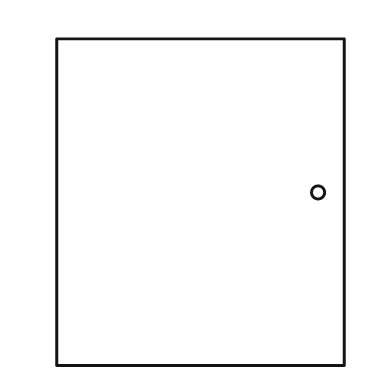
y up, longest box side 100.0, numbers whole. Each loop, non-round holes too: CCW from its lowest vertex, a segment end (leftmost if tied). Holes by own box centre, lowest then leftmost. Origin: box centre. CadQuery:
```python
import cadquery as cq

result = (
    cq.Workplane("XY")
    .moveTo(-44.0, -50.0)
    .lineTo(44.0, -50.0)
    .lineTo(44.0, 50.0)
    .lineTo(-44.0, 50.0)
    .close()
    .moveTo(36.0, 3.0)
    .circle(2.0)
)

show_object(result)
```